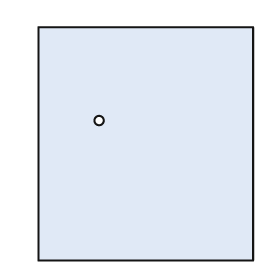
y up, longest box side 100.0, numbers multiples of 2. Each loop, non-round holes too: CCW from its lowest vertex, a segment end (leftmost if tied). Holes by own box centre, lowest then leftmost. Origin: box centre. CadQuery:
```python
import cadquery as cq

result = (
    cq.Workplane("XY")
    .moveTo(-46.0, -50.0)
    .lineTo(46.0, -50.0)
    .lineTo(46.0, 50.0)
    .lineTo(-46.0, 50.0)
    .close()
    .moveTo(-20.0, 10.0)
    .circle(2.0)
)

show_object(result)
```